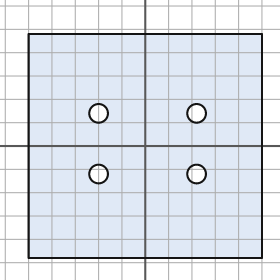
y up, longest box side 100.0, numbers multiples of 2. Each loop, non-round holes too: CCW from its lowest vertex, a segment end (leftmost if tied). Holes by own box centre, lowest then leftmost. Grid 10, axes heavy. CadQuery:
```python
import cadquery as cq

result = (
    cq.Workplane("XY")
    .moveTo(-50.0, -48.0)
    .lineTo(50.0, -48.0)
    .lineTo(50.0, 48.0)
    .lineTo(-50.0, 48.0)
    .close()
    .moveTo(-20.0, -12.0)
    .circle(4.0)
    .moveTo(22.0, -12.0)
    .circle(4.0)
    .moveTo(-20.0, 14.0)
    .circle(4.0)
    .moveTo(22.0, 14.0)
    .circle(4.0)
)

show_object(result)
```